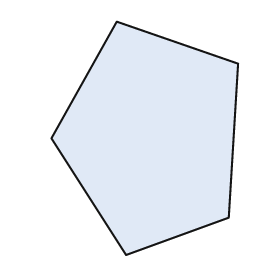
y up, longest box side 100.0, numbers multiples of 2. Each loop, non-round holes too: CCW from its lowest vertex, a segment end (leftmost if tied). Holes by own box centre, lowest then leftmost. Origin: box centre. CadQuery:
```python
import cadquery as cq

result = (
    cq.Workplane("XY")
    .moveTo(-8.0, -50.0)
    .lineTo(36.0, -34.0)
    .lineTo(40.0, 32.0)
    .lineTo(-12.0, 50.0)
    .lineTo(-40.0, 0.0)
    .close()
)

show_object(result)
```